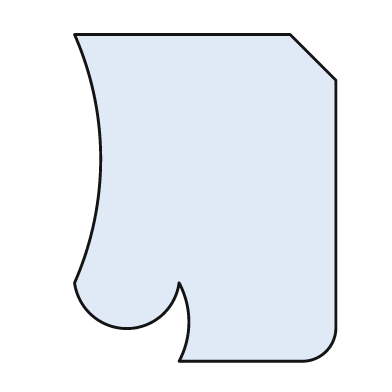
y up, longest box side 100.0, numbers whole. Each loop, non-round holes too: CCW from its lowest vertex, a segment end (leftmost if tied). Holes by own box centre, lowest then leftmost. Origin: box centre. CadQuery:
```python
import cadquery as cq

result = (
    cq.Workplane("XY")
    .moveTo(-8.0, -50.0)
    .lineTo(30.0, -50.0)
    .threePointArc((37.0, -47.0), (40.0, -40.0))
    .lineTo(40.0, 36.0)
    .lineTo(26.0, 50.0)
    .lineTo(-40.0, 50.0)
    .threePointArc((-32.0, 12.0), (-40.0, -26.0))
    .threePointArc((-24.0, -40.0), (-8.0, -26.0))
    .threePointArc((-5.0, -38.0), (-8.0, -50.0))
    .close()
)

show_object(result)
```